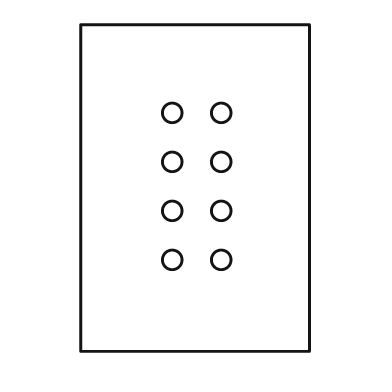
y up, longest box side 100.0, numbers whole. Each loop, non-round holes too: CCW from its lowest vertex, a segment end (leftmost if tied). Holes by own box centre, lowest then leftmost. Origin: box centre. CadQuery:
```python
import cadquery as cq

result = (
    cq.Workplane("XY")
    .moveTo(-35.0, -50.0)
    .lineTo(35.0, -50.0)
    .lineTo(35.0, 50.0)
    .lineTo(-35.0, 50.0)
    .close()
    .moveTo(-7.0, -22.0)
    .circle(3.0)
    .moveTo(8.0, -22.0)
    .circle(3.0)
    .moveTo(-7.0, -7.0)
    .circle(3.0)
    .moveTo(8.0, -7.0)
    .circle(3.0)
    .moveTo(-7.0, 8.0)
    .circle(3.0)
    .moveTo(8.0, 8.0)
    .circle(3.0)
    .moveTo(-7.0, 23.0)
    .circle(3.0)
    .moveTo(8.0, 23.0)
    .circle(3.0)
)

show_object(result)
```